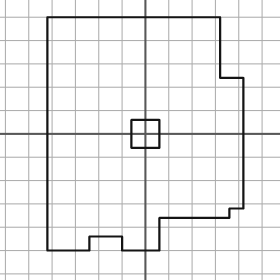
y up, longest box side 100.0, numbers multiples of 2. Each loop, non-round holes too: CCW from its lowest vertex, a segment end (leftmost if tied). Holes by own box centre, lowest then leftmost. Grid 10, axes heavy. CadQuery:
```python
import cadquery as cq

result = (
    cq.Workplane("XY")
    .moveTo(-42.0, -50.0)
    .lineTo(-24.0, -50.0)
    .lineTo(-24.0, -44.0)
    .lineTo(-10.0, -44.0)
    .lineTo(-10.0, -50.0)
    .lineTo(6.0, -50.0)
    .lineTo(6.0, -36.0)
    .lineTo(36.0, -36.0)
    .lineTo(36.0, -32.0)
    .lineTo(42.0, -32.0)
    .lineTo(42.0, 24.0)
    .lineTo(32.0, 24.0)
    .lineTo(32.0, 50.0)
    .lineTo(-42.0, 50.0)
    .close()
    .moveTo(-6.0, -6.0)
    .lineTo(6.0, -6.0)
    .lineTo(6.0, 6.0)
    .lineTo(-6.0, 6.0)
    .close()
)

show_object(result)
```